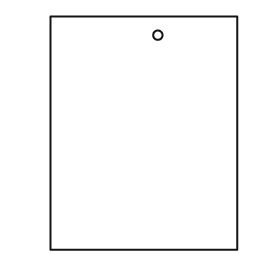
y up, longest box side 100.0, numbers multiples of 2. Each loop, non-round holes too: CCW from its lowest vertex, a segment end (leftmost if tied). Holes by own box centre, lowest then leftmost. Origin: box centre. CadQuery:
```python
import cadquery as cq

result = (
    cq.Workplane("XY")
    .moveTo(-40.0, -50.0)
    .lineTo(40.0, -50.0)
    .lineTo(40.0, 50.0)
    .lineTo(-40.0, 50.0)
    .close()
    .moveTo(6.0, 42.0)
    .circle(2.0)
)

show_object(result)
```